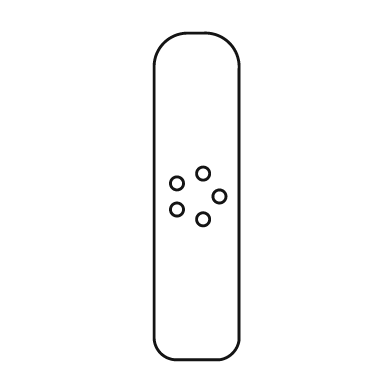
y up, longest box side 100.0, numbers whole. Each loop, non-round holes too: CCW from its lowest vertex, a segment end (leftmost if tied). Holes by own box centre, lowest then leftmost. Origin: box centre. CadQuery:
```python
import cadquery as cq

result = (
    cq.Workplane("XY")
    .moveTo(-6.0, -50.0)
    .lineTo(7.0, -50.0)
    .threePointArc((11.0, -48.0), (13.0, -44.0))
    .lineTo(13.0, 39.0)
    .threePointArc((10.0, 47.0), (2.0, 50.0))
    .lineTo(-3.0, 50.0)
    .threePointArc((-10.0, 47.0), (-13.0, 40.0))
    .lineTo(-13.0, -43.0)
    .threePointArc((-11.0, -48.0), (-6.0, -50.0))
    .close()
    .moveTo(2.0, -7.0)
    .circle(2.0)
    .moveTo(-6.0, -4.0)
    .circle(2.0)
    .moveTo(7.0, 0.0)
    .circle(2.0)
    .moveTo(-6.0, 4.0)
    .circle(2.0)
    .moveTo(2.0, 7.0)
    .circle(2.0)
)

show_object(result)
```